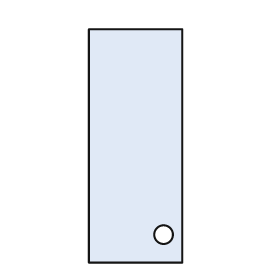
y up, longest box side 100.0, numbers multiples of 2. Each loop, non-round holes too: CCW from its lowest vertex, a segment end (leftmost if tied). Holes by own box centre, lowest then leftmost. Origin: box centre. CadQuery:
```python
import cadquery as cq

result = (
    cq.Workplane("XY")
    .moveTo(-20.0, -50.0)
    .lineTo(20.0, -50.0)
    .lineTo(20.0, 50.0)
    .lineTo(-20.0, 50.0)
    .close()
    .moveTo(12.0, -38.0)
    .circle(4.0)
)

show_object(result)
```